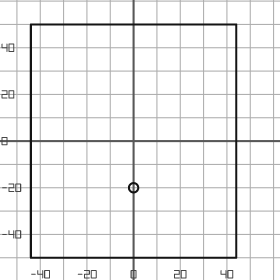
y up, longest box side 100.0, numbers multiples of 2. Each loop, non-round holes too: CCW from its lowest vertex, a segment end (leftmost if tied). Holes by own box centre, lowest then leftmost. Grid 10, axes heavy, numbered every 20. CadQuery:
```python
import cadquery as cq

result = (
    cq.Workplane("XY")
    .moveTo(-44.0, -50.0)
    .lineTo(44.0, -50.0)
    .lineTo(44.0, 50.0)
    .lineTo(-44.0, 50.0)
    .close()
    .moveTo(0.0, -20.0)
    .circle(2.0)
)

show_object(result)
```